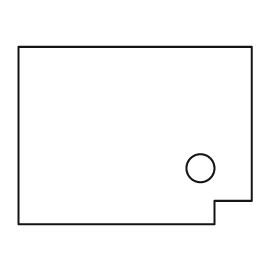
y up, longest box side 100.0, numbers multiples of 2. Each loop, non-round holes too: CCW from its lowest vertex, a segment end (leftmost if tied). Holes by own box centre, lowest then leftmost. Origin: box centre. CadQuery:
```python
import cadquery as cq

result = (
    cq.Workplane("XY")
    .moveTo(-50.0, -38.0)
    .lineTo(34.0, -38.0)
    .lineTo(34.0, -28.0)
    .lineTo(50.0, -28.0)
    .lineTo(50.0, 38.0)
    .lineTo(-50.0, 38.0)
    .close()
    .moveTo(28.0, -14.0)
    .circle(6.0)
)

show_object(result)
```